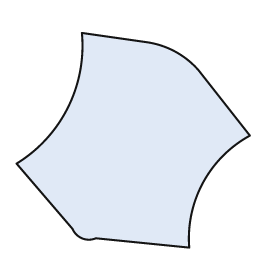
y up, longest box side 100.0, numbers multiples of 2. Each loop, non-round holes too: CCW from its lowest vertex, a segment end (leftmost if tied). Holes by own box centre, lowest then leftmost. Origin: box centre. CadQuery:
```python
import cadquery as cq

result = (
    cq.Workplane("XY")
    .moveTo(24.0, -46.0)
    .threePointArc((30.0, -18.0), (50.0, 2.0))
    .lineTo(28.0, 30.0)
    .threePointArc((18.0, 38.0), (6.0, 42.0))
    .lineTo(-22.0, 46.0)
    .threePointArc((-28.0, 14.0), (-50.0, -10.0))
    .lineTo(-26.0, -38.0)
    .threePointArc((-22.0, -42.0), (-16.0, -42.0))
    .close()
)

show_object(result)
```